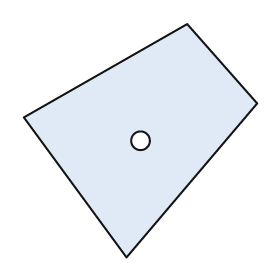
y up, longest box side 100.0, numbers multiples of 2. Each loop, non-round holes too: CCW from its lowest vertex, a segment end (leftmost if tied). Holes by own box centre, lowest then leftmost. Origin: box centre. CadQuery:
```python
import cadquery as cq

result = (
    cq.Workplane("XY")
    .moveTo(-6.0, -50.0)
    .lineTo(50.0, 16.0)
    .lineTo(20.0, 50.0)
    .lineTo(-50.0, 10.0)
    .close()
    .moveTo(0.0, 0.0)
    .circle(4.0)
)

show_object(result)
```